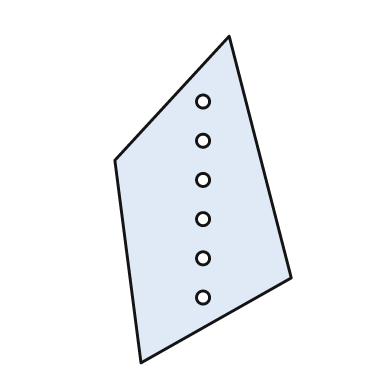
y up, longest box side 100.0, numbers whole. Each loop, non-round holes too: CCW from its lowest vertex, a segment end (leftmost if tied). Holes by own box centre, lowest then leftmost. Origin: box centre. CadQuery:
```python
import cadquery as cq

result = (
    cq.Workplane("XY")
    .moveTo(-19.0, -50.0)
    .lineTo(27.0, -24.0)
    .lineTo(8.0, 50.0)
    .lineTo(-27.0, 12.0)
    .close()
    .moveTo(0.0, -30.0)
    .circle(2.0)
    .moveTo(0.0, -18.0)
    .circle(2.0)
    .moveTo(0.0, -6.0)
    .circle(2.0)
    .moveTo(0.0, 6.0)
    .circle(2.0)
    .moveTo(0.0, 18.0)
    .circle(2.0)
    .moveTo(0.0, 30.0)
    .circle(2.0)
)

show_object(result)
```